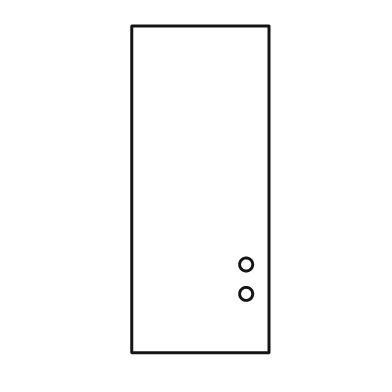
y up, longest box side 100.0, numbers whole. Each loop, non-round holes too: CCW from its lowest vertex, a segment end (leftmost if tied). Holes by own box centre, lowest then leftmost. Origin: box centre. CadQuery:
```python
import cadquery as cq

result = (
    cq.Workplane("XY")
    .moveTo(-21.0, -50.0)
    .lineTo(21.0, -50.0)
    .lineTo(21.0, 50.0)
    .lineTo(-21.0, 50.0)
    .close()
    .moveTo(14.0, -32.0)
    .circle(2.0)
    .moveTo(14.0, -23.0)
    .circle(2.0)
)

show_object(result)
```